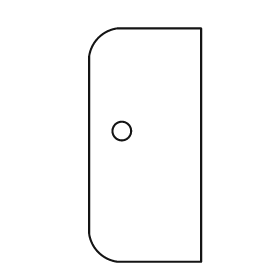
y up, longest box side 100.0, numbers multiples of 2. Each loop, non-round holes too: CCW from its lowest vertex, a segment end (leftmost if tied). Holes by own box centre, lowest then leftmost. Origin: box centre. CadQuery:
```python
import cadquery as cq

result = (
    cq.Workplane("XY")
    .moveTo(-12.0, -50.0)
    .lineTo(24.0, -50.0)
    .lineTo(24.0, 50.0)
    .lineTo(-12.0, 50.0)
    .threePointArc((-20.0, 46.0), (-24.0, 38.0))
    .lineTo(-24.0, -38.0)
    .threePointArc((-20.0, -46.0), (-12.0, -50.0))
    .close()
    .moveTo(-10.0, 6.0)
    .circle(4.0)
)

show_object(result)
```